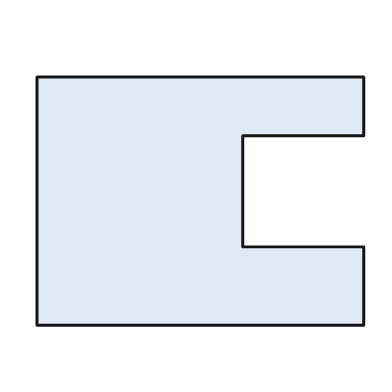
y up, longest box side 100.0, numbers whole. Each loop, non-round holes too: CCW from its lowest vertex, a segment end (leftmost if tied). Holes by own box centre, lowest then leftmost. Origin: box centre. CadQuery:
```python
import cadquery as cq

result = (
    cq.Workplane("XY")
    .moveTo(-50.0, -38.0)
    .lineTo(50.0, -38.0)
    .lineTo(50.0, -14.0)
    .lineTo(13.0, -14.0)
    .lineTo(13.0, 20.0)
    .lineTo(50.0, 20.0)
    .lineTo(50.0, 38.0)
    .lineTo(-50.0, 38.0)
    .close()
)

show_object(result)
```